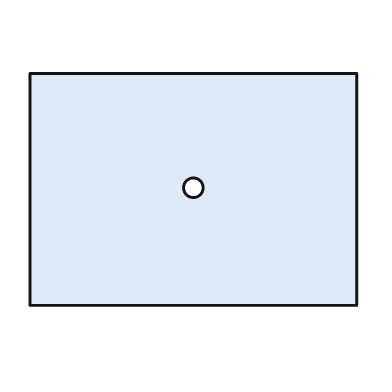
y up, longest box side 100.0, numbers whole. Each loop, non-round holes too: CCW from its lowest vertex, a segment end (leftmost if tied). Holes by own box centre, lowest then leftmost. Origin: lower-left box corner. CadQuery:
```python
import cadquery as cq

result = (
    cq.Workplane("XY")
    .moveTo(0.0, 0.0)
    .lineTo(100.0, 0.0)
    .lineTo(100.0, 71.0)
    .lineTo(0.0, 71.0)
    .close()
    .moveTo(50.0, 36.0)
    .circle(3.0)
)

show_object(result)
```